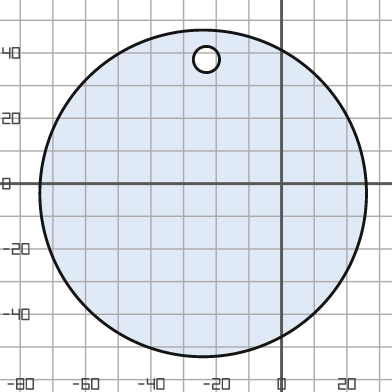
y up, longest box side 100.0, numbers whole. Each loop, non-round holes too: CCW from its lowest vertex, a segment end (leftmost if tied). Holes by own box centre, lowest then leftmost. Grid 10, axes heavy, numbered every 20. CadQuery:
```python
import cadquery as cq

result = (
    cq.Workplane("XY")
    .moveTo(-24.0, -3.0)
    .circle(50.0)
    .moveTo(-23.0, 38.0)
    .circle(4.0)
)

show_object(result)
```